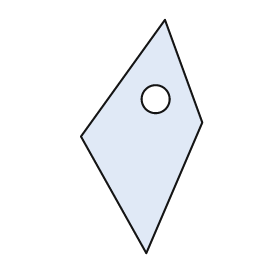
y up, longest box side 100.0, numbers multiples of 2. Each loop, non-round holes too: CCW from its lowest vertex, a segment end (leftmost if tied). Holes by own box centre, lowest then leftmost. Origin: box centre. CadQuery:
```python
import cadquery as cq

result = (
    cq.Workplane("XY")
    .moveTo(2.0, -50.0)
    .lineTo(26.0, 6.0)
    .lineTo(10.0, 50.0)
    .lineTo(-26.0, 0.0)
    .close()
    .moveTo(6.0, 16.0)
    .circle(6.0)
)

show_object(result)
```